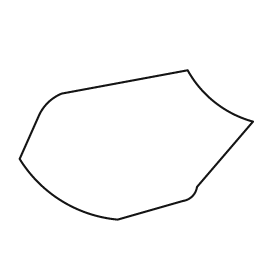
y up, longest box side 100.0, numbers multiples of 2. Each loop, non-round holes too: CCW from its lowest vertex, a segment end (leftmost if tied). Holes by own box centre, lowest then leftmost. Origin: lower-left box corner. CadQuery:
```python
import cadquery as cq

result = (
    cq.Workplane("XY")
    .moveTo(42.0, 0.0)
    .lineTo(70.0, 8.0)
    .threePointArc((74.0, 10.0), (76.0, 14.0))
    .lineTo(100.0, 42.0)
    .threePointArc((84.0, 50.0), (72.0, 64.0))
    .lineTo(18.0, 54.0)
    .threePointArc((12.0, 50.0), (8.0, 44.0))
    .lineTo(0.0, 26.0)
    .threePointArc((18.0, 8.0), (42.0, 0.0))
    .close()
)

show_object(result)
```